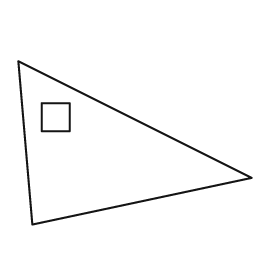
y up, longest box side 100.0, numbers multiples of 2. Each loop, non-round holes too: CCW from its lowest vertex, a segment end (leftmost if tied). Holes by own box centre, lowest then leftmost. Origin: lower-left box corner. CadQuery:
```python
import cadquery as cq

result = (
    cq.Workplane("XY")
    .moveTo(6.0, 0.0)
    .lineTo(100.0, 20.0)
    .lineTo(0.0, 70.0)
    .close()
    .moveTo(10.0, 40.0)
    .lineTo(22.0, 40.0)
    .lineTo(22.0, 52.0)
    .lineTo(10.0, 52.0)
    .close()
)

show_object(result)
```